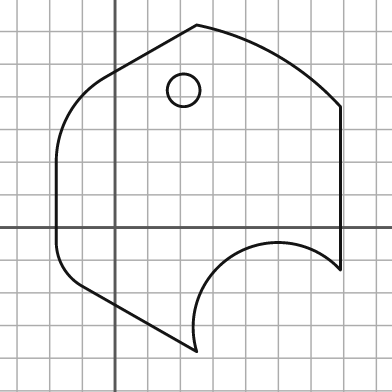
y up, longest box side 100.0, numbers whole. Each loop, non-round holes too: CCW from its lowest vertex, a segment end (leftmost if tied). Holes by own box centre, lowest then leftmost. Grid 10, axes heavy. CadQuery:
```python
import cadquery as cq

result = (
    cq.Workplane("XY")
    .moveTo(25.0, -38.0)
    .threePointArc((37.0, -8.0), (69.0, -13.0))
    .lineTo(69.0, 37.0)
    .threePointArc((49.0, 53.0), (25.0, 62.0))
    .lineTo(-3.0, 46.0)
    .threePointArc((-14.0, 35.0), (-18.0, 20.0))
    .lineTo(-18.0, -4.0)
    .threePointArc((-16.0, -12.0), (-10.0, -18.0))
    .close()
    .moveTo(21.0, 42.0)
    .circle(5.0)
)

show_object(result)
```